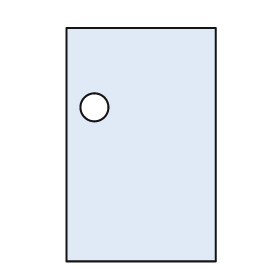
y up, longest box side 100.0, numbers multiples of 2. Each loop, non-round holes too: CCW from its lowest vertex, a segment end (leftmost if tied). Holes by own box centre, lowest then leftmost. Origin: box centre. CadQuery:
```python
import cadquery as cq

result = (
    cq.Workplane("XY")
    .moveTo(-32.0, -50.0)
    .lineTo(32.0, -50.0)
    .lineTo(32.0, 50.0)
    .lineTo(-32.0, 50.0)
    .close()
    .moveTo(-20.0, 16.0)
    .circle(6.0)
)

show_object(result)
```